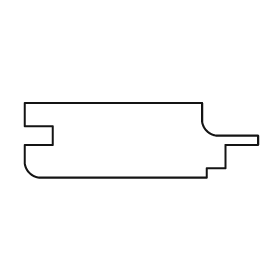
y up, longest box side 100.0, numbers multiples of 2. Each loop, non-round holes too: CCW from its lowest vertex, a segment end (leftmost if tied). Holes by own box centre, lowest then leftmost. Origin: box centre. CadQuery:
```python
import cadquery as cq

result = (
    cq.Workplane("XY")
    .moveTo(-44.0, -16.0)
    .lineTo(28.0, -16.0)
    .lineTo(28.0, -12.0)
    .lineTo(36.0, -12.0)
    .lineTo(36.0, -2.0)
    .lineTo(50.0, -2.0)
    .lineTo(50.0, 2.0)
    .lineTo(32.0, 2.0)
    .threePointArc((28.0, 4.0), (26.0, 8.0))
    .lineTo(26.0, 16.0)
    .lineTo(-50.0, 16.0)
    .lineTo(-50.0, 6.0)
    .lineTo(-38.0, 6.0)
    .lineTo(-38.0, -2.0)
    .lineTo(-50.0, -2.0)
    .lineTo(-50.0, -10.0)
    .threePointArc((-48.0, -14.0), (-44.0, -16.0))
    .close()
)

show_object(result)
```